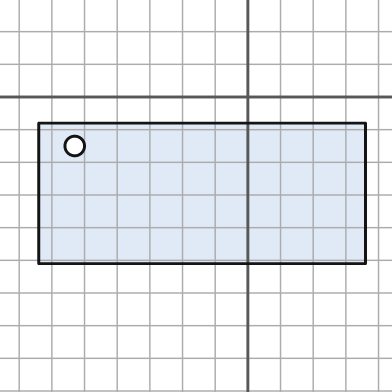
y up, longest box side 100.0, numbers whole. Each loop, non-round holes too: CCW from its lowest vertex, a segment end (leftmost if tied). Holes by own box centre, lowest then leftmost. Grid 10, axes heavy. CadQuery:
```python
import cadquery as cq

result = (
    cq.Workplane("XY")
    .moveTo(-64.0, -51.0)
    .lineTo(36.0, -51.0)
    .lineTo(36.0, -8.0)
    .lineTo(-64.0, -8.0)
    .close()
    .moveTo(-53.0, -15.0)
    .circle(3.0)
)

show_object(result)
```